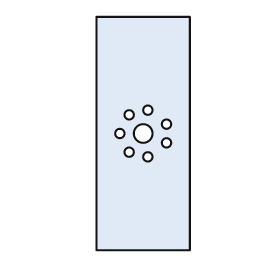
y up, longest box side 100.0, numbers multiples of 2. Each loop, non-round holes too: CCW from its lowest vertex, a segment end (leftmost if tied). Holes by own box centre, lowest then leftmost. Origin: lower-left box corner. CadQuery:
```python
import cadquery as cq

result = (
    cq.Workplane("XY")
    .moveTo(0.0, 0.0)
    .lineTo(40.0, 0.0)
    .lineTo(40.0, 100.0)
    .lineTo(0.0, 100.0)
    .close()
    .moveTo(22.0, 40.0)
    .circle(2.0)
    .moveTo(14.0, 42.0)
    .circle(2.0)
    .moveTo(30.0, 46.0)
    .circle(2.0)
    .moveTo(10.0, 50.0)
    .circle(2.0)
    .moveTo(20.0, 50.0)
    .circle(4.0)
    .moveTo(30.0, 54.0)
    .circle(2.0)
    .moveTo(14.0, 58.0)
    .circle(2.0)
    .moveTo(22.0, 60.0)
    .circle(2.0)
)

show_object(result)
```